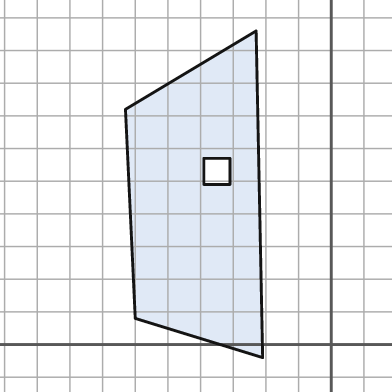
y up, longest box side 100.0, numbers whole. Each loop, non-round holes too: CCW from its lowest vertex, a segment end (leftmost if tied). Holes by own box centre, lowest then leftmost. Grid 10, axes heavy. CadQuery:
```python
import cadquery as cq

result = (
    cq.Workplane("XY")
    .moveTo(-21.0, -4.0)
    .lineTo(-23.0, 96.0)
    .lineTo(-63.0, 72.0)
    .lineTo(-60.0, 8.0)
    .close()
    .moveTo(-39.0, 49.0)
    .lineTo(-31.0, 49.0)
    .lineTo(-31.0, 57.0)
    .lineTo(-39.0, 57.0)
    .close()
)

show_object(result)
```